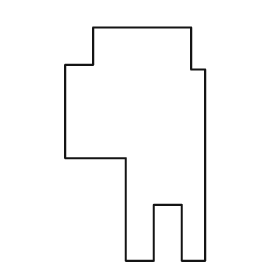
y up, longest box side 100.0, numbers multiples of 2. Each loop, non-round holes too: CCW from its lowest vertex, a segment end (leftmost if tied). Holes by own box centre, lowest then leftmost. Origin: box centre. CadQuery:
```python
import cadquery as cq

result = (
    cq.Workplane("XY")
    .moveTo(-4.0, -50.0)
    .lineTo(8.0, -50.0)
    .lineTo(8.0, -26.0)
    .lineTo(20.0, -26.0)
    .lineTo(20.0, -50.0)
    .lineTo(30.0, -50.0)
    .lineTo(30.0, 32.0)
    .lineTo(24.0, 32.0)
    .lineTo(24.0, 50.0)
    .lineTo(-18.0, 50.0)
    .lineTo(-18.0, 34.0)
    .lineTo(-30.0, 34.0)
    .lineTo(-30.0, -6.0)
    .lineTo(-4.0, -6.0)
    .close()
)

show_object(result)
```